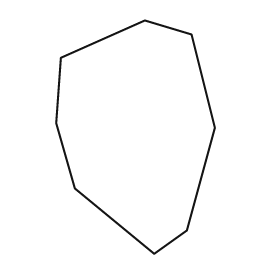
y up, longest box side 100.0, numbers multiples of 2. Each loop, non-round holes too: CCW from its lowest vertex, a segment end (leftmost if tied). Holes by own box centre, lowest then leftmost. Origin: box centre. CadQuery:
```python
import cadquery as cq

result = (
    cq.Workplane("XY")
    .moveTo(8.0, -50.0)
    .lineTo(22.0, -40.0)
    .lineTo(34.0, 4.0)
    .lineTo(24.0, 44.0)
    .lineTo(4.0, 50.0)
    .lineTo(-32.0, 34.0)
    .lineTo(-34.0, 6.0)
    .lineTo(-26.0, -22.0)
    .close()
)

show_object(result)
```